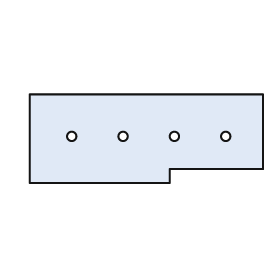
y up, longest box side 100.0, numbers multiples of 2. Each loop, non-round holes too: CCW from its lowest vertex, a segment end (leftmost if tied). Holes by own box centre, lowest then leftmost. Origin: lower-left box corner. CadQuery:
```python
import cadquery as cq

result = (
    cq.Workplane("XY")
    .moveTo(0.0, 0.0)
    .lineTo(60.0, 0.0)
    .lineTo(60.0, 6.0)
    .lineTo(100.0, 6.0)
    .lineTo(100.0, 38.0)
    .lineTo(0.0, 38.0)
    .close()
    .moveTo(18.0, 20.0)
    .circle(2.0)
    .moveTo(40.0, 20.0)
    .circle(2.0)
    .moveTo(62.0, 20.0)
    .circle(2.0)
    .moveTo(84.0, 20.0)
    .circle(2.0)
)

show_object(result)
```